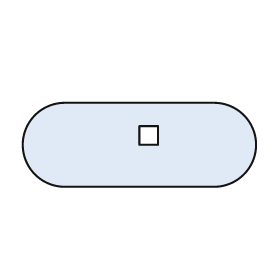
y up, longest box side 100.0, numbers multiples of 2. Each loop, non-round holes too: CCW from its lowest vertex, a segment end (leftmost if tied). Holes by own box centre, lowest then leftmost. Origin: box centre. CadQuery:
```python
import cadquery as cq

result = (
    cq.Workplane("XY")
    .moveTo(-32.0, -18.0)
    .lineTo(32.0, -18.0)
    .threePointArc((50.0, 0.0), (32.0, 18.0))
    .lineTo(-32.0, 18.0)
    .threePointArc((-50.0, 0.0), (-32.0, -18.0))
    .close()
    .moveTo(0.0, 0.0)
    .lineTo(8.0, 0.0)
    .lineTo(8.0, 8.0)
    .lineTo(0.0, 8.0)
    .close()
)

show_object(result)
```